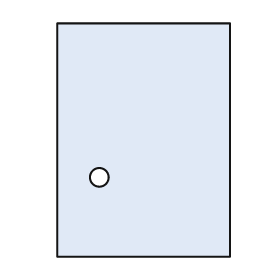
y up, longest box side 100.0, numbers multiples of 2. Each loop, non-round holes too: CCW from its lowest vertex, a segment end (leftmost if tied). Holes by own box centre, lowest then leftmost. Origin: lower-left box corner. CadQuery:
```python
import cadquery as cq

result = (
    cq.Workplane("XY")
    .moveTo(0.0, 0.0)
    .lineTo(74.0, 0.0)
    .lineTo(74.0, 100.0)
    .lineTo(0.0, 100.0)
    .close()
    .moveTo(18.0, 34.0)
    .circle(4.0)
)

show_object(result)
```